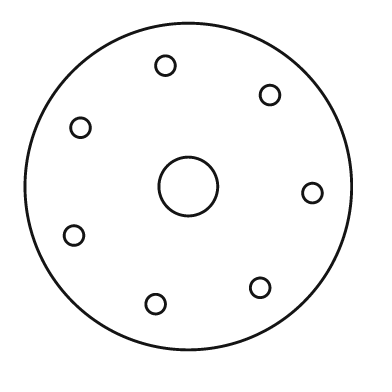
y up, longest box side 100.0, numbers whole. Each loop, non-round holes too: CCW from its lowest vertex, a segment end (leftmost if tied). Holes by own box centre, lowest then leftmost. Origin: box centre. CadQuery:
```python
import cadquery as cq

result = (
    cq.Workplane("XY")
    .moveTo(0.0, 0.0)
    .circle(50.0)
    .moveTo(-10.0, -36.0)
    .circle(3.0)
    .moveTo(22.0, -31.0)
    .circle(3.0)
    .moveTo(-35.0, -15.0)
    .circle(3.0)
    .moveTo(38.0, -2.0)
    .circle(3.0)
    .moveTo(0.0, 0.0)
    .circle(9.0)
    .moveTo(-33.0, 18.0)
    .circle(3.0)
    .moveTo(25.0, 28.0)
    .circle(3.0)
    .moveTo(-7.0, 37.0)
    .circle(3.0)
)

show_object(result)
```